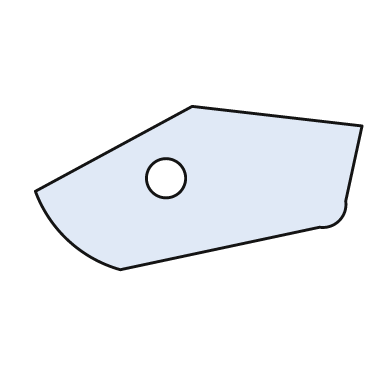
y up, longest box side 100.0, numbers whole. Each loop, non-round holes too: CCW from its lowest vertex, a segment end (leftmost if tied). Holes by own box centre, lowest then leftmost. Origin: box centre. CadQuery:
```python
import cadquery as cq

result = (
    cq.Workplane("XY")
    .moveTo(-24.0, -25.0)
    .lineTo(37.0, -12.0)
    .threePointArc((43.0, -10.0), (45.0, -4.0))
    .lineTo(50.0, 19.0)
    .lineTo(-2.0, 25.0)
    .lineTo(-50.0, -1.0)
    .threePointArc((-40.0, -16.0), (-24.0, -25.0))
    .close()
    .moveTo(-10.0, 3.0)
    .circle(6.0)
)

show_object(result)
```